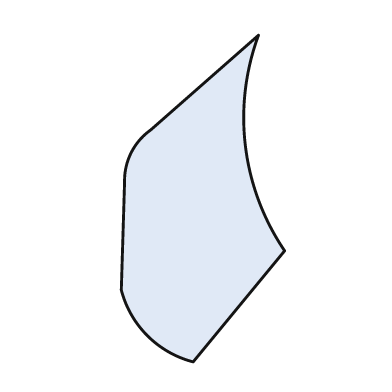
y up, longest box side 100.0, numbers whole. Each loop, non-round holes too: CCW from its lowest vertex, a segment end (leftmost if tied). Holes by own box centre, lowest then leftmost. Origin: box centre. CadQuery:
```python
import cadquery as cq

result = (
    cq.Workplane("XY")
    .moveTo(-3.0, -50.0)
    .lineTo(25.0, -16.0)
    .threePointArc((13.0, 16.0), (17.0, 50.0))
    .lineTo(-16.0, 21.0)
    .threePointArc((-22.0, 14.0), (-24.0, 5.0))
    .lineTo(-25.0, -28.0)
    .threePointArc((-17.0, -42.0), (-3.0, -50.0))
    .close()
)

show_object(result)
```